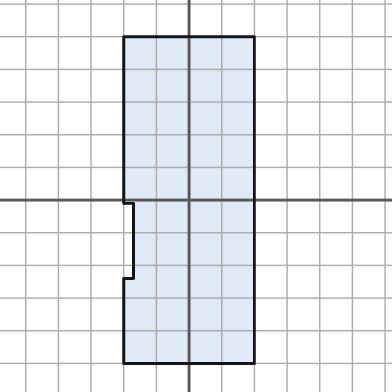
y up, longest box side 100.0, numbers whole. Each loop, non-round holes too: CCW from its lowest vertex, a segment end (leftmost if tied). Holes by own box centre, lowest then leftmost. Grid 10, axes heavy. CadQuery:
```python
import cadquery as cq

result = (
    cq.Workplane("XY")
    .moveTo(-20.0, -50.0)
    .lineTo(20.0, -50.0)
    .lineTo(20.0, 50.0)
    .lineTo(-20.0, 50.0)
    .lineTo(-20.0, -1.0)
    .lineTo(-17.0, -1.0)
    .lineTo(-17.0, -24.0)
    .lineTo(-20.0, -24.0)
    .close()
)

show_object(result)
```